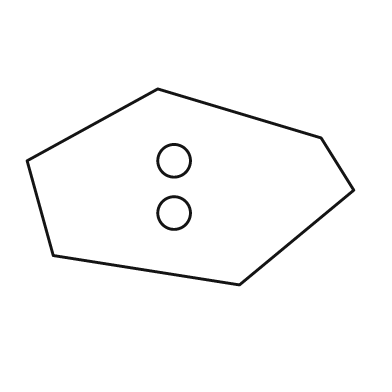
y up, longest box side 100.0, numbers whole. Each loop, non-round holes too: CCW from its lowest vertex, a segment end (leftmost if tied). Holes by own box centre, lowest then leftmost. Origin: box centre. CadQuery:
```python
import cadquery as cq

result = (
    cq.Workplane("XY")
    .moveTo(15.0, -30.0)
    .lineTo(50.0, -1.0)
    .lineTo(40.0, 15.0)
    .lineTo(-10.0, 30.0)
    .lineTo(-50.0, 8.0)
    .lineTo(-42.0, -21.0)
    .close()
    .moveTo(-5.0, -8.0)
    .circle(5.0)
    .moveTo(-5.0, 8.0)
    .circle(5.0)
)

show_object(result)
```